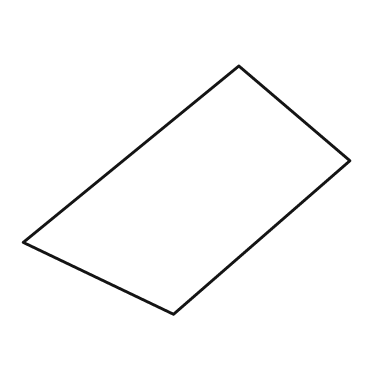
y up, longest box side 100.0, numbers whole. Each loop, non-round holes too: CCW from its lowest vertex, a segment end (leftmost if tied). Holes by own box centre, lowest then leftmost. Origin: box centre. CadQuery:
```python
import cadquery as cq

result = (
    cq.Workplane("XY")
    .moveTo(-4.0, -38.0)
    .lineTo(50.0, 9.0)
    .lineTo(16.0, 38.0)
    .lineTo(-50.0, -16.0)
    .close()
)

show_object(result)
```